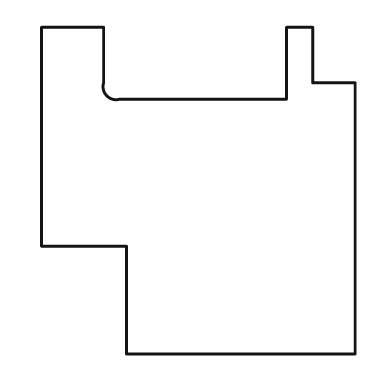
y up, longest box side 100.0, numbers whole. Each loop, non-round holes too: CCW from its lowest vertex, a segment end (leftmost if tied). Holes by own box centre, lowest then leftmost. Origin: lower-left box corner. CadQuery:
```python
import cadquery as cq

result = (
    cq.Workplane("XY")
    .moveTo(26.0, 0.0)
    .lineTo(96.0, 0.0)
    .lineTo(96.0, 83.0)
    .lineTo(83.0, 83.0)
    .lineTo(83.0, 100.0)
    .lineTo(75.0, 100.0)
    .lineTo(75.0, 78.0)
    .lineTo(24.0, 78.0)
    .threePointArc((20.0, 79.0), (19.0, 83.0))
    .lineTo(19.0, 100.0)
    .lineTo(0.0, 100.0)
    .lineTo(0.0, 33.0)
    .lineTo(26.0, 33.0)
    .close()
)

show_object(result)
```